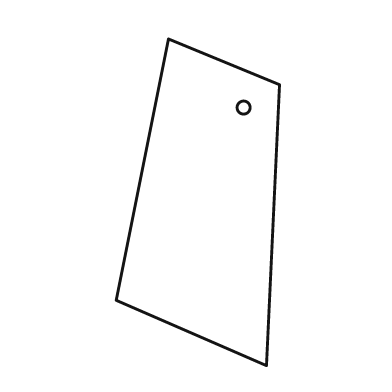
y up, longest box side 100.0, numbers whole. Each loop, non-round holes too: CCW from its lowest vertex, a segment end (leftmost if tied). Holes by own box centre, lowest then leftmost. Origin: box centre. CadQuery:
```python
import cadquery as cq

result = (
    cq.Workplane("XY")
    .moveTo(21.0, -50.0)
    .lineTo(25.0, 36.0)
    .lineTo(-9.0, 50.0)
    .lineTo(-25.0, -30.0)
    .close()
    .moveTo(14.0, 29.0)
    .circle(2.0)
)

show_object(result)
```